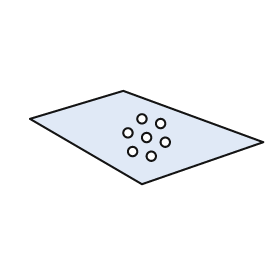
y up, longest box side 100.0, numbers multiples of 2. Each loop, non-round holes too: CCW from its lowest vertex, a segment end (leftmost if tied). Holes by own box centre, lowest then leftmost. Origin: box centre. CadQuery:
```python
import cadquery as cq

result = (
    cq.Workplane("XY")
    .moveTo(-2.0, -20.0)
    .lineTo(50.0, -2.0)
    .lineTo(-10.0, 20.0)
    .lineTo(-50.0, 8.0)
    .close()
    .moveTo(2.0, -8.0)
    .circle(2.0)
    .moveTo(-6.0, -6.0)
    .circle(2.0)
    .moveTo(8.0, -2.0)
    .circle(2.0)
    .moveTo(0.0, 0.0)
    .circle(2.0)
    .moveTo(-8.0, 2.0)
    .circle(2.0)
    .moveTo(6.0, 6.0)
    .circle(2.0)
    .moveTo(-2.0, 8.0)
    .circle(2.0)
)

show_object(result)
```